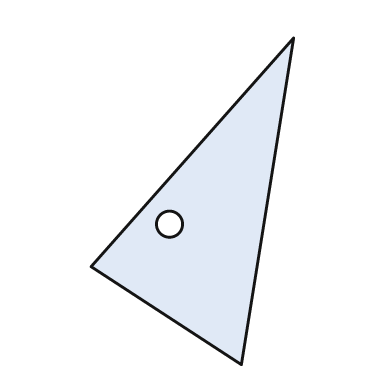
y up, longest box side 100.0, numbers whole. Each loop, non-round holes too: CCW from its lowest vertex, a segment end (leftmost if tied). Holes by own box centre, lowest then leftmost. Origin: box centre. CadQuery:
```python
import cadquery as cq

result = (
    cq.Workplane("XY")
    .moveTo(15.0, -50.0)
    .lineTo(31.0, 50.0)
    .lineTo(-31.0, -20.0)
    .close()
    .moveTo(-7.0, -7.0)
    .circle(4.0)
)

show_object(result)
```